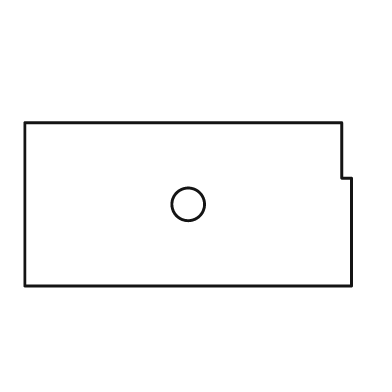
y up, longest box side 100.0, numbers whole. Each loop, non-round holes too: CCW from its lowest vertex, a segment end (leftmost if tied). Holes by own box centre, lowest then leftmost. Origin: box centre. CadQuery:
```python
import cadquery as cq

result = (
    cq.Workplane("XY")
    .moveTo(-50.0, -25.0)
    .lineTo(50.0, -25.0)
    .lineTo(50.0, 8.0)
    .lineTo(47.0, 8.0)
    .lineTo(47.0, 25.0)
    .lineTo(-50.0, 25.0)
    .close()
    .moveTo(0.0, 0.0)
    .circle(5.0)
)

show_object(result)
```